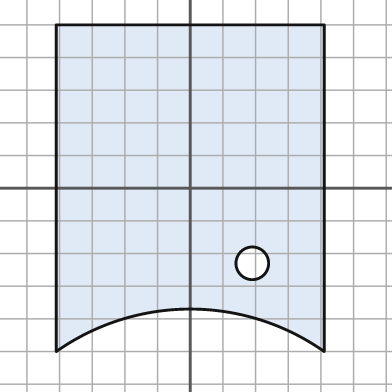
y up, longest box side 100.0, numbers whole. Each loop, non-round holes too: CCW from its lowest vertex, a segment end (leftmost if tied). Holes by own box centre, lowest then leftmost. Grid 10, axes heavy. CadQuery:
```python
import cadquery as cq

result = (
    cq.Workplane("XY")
    .moveTo(-41.0, -50.0)
    .threePointArc((0.0, -37.0), (41.0, -50.0))
    .lineTo(41.0, 50.0)
    .lineTo(-41.0, 50.0)
    .close()
    .moveTo(19.0, -23.0)
    .circle(5.0)
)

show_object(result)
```